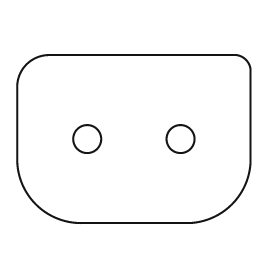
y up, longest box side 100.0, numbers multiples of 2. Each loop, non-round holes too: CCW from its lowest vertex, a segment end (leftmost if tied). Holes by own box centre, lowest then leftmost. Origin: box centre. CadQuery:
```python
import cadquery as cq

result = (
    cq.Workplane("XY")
    .moveTo(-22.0, -36.0)
    .lineTo(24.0, -36.0)
    .threePointArc((42.0, -28.0), (50.0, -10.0))
    .lineTo(50.0, 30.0)
    .threePointArc((48.0, 34.0), (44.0, 36.0))
    .lineTo(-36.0, 36.0)
    .threePointArc((-46.0, 32.0), (-50.0, 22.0))
    .lineTo(-50.0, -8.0)
    .threePointArc((-42.0, -28.0), (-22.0, -36.0))
    .close()
    .moveTo(-20.0, 0.0)
    .circle(6.0)
    .moveTo(20.0, 0.0)
    .circle(6.0)
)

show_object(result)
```